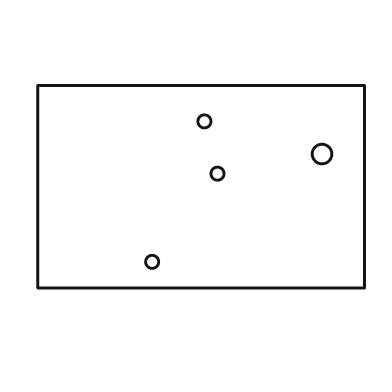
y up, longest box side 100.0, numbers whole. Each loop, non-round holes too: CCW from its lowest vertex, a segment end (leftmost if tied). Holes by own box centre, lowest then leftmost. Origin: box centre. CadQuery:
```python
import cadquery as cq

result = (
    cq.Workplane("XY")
    .moveTo(-50.0, -31.0)
    .lineTo(50.0, -31.0)
    .lineTo(50.0, 31.0)
    .lineTo(-50.0, 31.0)
    .close()
    .moveTo(-15.0, -23.0)
    .circle(2.0)
    .moveTo(5.0, 4.0)
    .circle(2.0)
    .moveTo(37.0, 10.0)
    .circle(3.0)
    .moveTo(1.0, 20.0)
    .circle(2.0)
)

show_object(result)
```